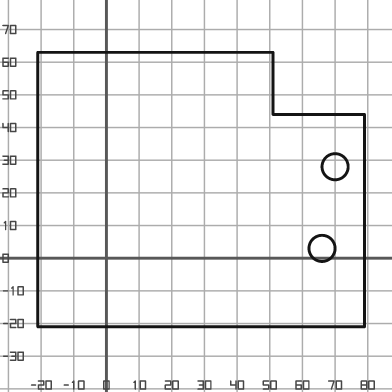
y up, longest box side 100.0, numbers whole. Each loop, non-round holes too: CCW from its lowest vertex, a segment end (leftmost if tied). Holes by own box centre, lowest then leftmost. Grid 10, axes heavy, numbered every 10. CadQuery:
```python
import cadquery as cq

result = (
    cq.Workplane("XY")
    .moveTo(-21.0, -21.0)
    .lineTo(79.0, -21.0)
    .lineTo(79.0, 44.0)
    .lineTo(51.0, 44.0)
    .lineTo(51.0, 63.0)
    .lineTo(-21.0, 63.0)
    .close()
    .moveTo(66.0, 3.0)
    .circle(4.0)
    .moveTo(70.0, 28.0)
    .circle(4.0)
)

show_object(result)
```